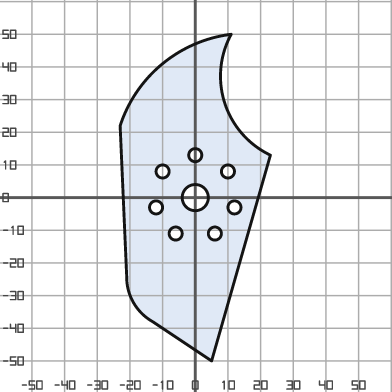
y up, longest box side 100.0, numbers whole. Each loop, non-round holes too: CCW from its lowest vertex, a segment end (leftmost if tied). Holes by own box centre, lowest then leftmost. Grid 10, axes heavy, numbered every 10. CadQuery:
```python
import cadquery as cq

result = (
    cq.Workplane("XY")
    .moveTo(5.0, -50.0)
    .lineTo(23.0, 13.0)
    .threePointArc((9.0, 29.0), (11.0, 50.0))
    .threePointArc((-10.0, 41.0), (-23.0, 22.0))
    .lineTo(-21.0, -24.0)
    .threePointArc((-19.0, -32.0), (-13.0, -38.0))
    .close()
    .moveTo(-6.0, -11.0)
    .circle(2.0)
    .moveTo(6.0, -11.0)
    .circle(2.0)
    .moveTo(-12.0, -3.0)
    .circle(2.0)
    .moveTo(12.0, -3.0)
    .circle(2.0)
    .moveTo(0.0, 0.0)
    .circle(4.0)
    .moveTo(-10.0, 8.0)
    .circle(2.0)
    .moveTo(10.0, 8.0)
    .circle(2.0)
    .moveTo(0.0, 13.0)
    .circle(2.0)
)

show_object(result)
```